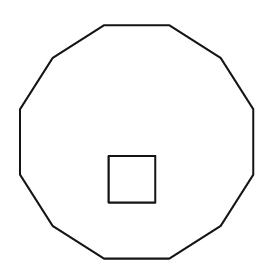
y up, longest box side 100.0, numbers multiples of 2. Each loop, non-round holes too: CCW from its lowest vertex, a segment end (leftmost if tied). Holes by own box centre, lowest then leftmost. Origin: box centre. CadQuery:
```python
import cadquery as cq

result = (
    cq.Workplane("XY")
    .moveTo(-14.0, -50.0)
    .lineTo(14.0, -50.0)
    .lineTo(36.0, -36.0)
    .lineTo(50.0, -14.0)
    .lineTo(50.0, 14.0)
    .lineTo(36.0, 36.0)
    .lineTo(14.0, 50.0)
    .lineTo(-14.0, 50.0)
    .lineTo(-36.0, 36.0)
    .lineTo(-50.0, 14.0)
    .lineTo(-50.0, -14.0)
    .lineTo(-36.0, -36.0)
    .close()
    .moveTo(-12.0, -26.0)
    .lineTo(8.0, -26.0)
    .lineTo(8.0, -6.0)
    .lineTo(-12.0, -6.0)
    .close()
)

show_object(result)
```